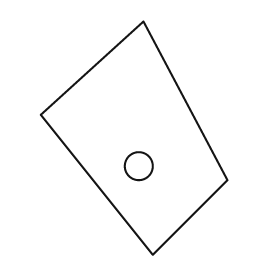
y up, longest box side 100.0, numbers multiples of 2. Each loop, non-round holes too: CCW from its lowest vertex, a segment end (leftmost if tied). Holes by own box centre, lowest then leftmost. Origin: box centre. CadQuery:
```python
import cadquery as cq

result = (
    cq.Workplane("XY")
    .moveTo(8.0, -50.0)
    .lineTo(40.0, -18.0)
    .lineTo(4.0, 50.0)
    .lineTo(-40.0, 10.0)
    .close()
    .moveTo(2.0, -12.0)
    .circle(6.0)
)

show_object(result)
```